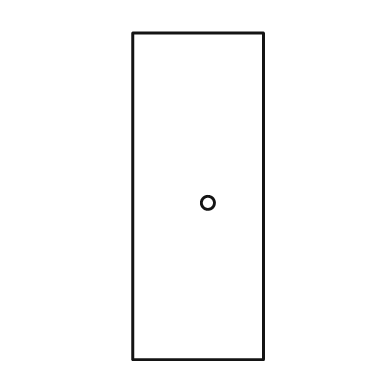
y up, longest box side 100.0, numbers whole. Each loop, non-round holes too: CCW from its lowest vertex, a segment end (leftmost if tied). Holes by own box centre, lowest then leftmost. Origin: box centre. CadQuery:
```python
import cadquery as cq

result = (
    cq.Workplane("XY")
    .moveTo(-20.0, -50.0)
    .lineTo(20.0, -50.0)
    .lineTo(20.0, 50.0)
    .lineTo(-20.0, 50.0)
    .close()
    .moveTo(3.0, -2.0)
    .circle(2.0)
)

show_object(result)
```